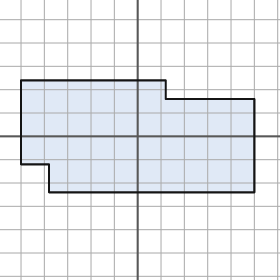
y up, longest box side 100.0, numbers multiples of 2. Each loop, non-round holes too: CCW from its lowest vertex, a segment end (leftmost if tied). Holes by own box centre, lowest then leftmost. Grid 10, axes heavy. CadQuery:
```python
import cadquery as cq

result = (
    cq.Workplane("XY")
    .moveTo(-38.0, -24.0)
    .lineTo(50.0, -24.0)
    .lineTo(50.0, 16.0)
    .lineTo(12.0, 16.0)
    .lineTo(12.0, 24.0)
    .lineTo(-50.0, 24.0)
    .lineTo(-50.0, -12.0)
    .lineTo(-38.0, -12.0)
    .close()
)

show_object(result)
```